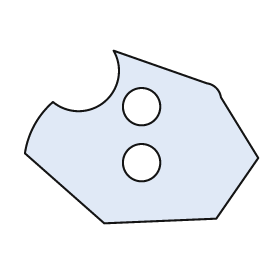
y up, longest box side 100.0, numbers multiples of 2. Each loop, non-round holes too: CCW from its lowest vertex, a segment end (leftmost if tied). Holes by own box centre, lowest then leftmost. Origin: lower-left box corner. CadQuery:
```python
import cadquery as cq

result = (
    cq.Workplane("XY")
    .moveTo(34.0, 0.0)
    .lineTo(82.0, 2.0)
    .lineTo(100.0, 28.0)
    .lineTo(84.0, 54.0)
    .threePointArc((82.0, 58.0), (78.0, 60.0))
    .lineTo(38.0, 74.0)
    .threePointArc((34.0, 52.0), (12.0, 52.0))
    .threePointArc((4.0, 42.0), (0.0, 30.0))
    .close()
    .moveTo(50.0, 26.0)
    .circle(8.0)
    .moveTo(50.0, 50.0)
    .circle(8.0)
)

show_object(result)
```